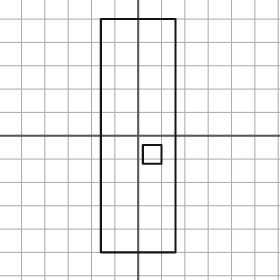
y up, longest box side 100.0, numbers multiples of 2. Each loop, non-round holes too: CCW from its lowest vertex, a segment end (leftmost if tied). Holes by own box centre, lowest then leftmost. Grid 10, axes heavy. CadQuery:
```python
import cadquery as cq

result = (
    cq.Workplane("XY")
    .moveTo(-16.0, -50.0)
    .lineTo(16.0, -50.0)
    .lineTo(16.0, 50.0)
    .lineTo(-16.0, 50.0)
    .close()
    .moveTo(2.0, -12.0)
    .lineTo(10.0, -12.0)
    .lineTo(10.0, -4.0)
    .lineTo(2.0, -4.0)
    .close()
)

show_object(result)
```